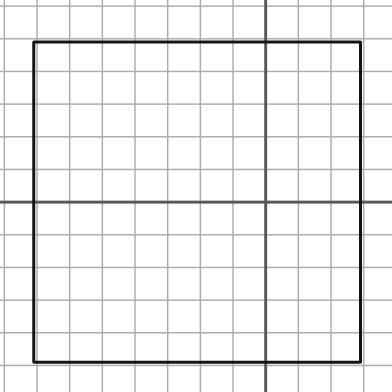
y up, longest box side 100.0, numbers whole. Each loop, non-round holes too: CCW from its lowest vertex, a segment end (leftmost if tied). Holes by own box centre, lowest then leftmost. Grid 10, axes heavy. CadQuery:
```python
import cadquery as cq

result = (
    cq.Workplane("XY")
    .moveTo(-71.0, -49.0)
    .lineTo(29.0, -49.0)
    .lineTo(29.0, 49.0)
    .lineTo(-71.0, 49.0)
    .close()
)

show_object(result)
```